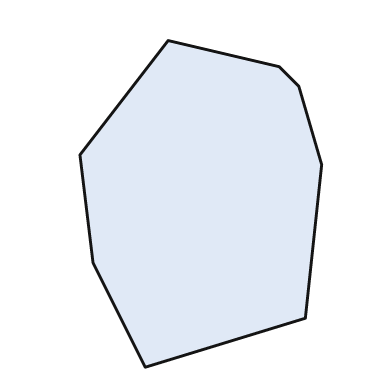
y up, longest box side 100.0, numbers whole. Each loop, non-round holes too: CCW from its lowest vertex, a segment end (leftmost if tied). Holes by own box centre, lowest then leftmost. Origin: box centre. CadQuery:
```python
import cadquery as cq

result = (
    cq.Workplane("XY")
    .moveTo(-17.0, -50.0)
    .lineTo(32.0, -35.0)
    .lineTo(37.0, 12.0)
    .lineTo(30.0, 36.0)
    .lineTo(24.0, 42.0)
    .lineTo(-10.0, 50.0)
    .lineTo(-37.0, 15.0)
    .lineTo(-33.0, -18.0)
    .close()
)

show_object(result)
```